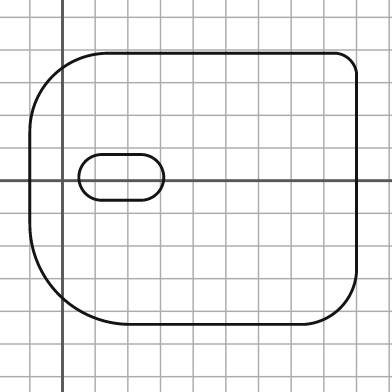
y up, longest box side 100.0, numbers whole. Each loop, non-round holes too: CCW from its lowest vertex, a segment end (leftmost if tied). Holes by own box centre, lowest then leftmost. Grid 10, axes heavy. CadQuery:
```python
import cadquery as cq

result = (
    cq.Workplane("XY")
    .moveTo(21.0, -44.0)
    .lineTo(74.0, -44.0)
    .threePointArc((85.0, -39.0), (90.0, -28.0))
    .lineTo(90.0, 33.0)
    .threePointArc((88.0, 37.0), (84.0, 39.0))
    .lineTo(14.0, 39.0)
    .threePointArc((-3.0, 32.0), (-10.0, 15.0))
    .lineTo(-10.0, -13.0)
    .threePointArc((-1.0, -35.0), (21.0, -44.0))
    .close()
    .moveTo(12.0, -6.0)
    .lineTo(24.0, -6.0)
    .threePointArc((31.0, 1.0), (24.0, 8.0))
    .lineTo(12.0, 8.0)
    .threePointArc((5.0, 1.0), (12.0, -6.0))
    .close()
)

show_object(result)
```